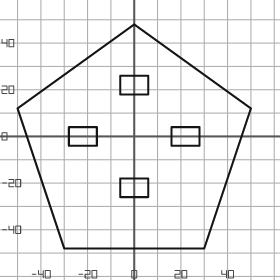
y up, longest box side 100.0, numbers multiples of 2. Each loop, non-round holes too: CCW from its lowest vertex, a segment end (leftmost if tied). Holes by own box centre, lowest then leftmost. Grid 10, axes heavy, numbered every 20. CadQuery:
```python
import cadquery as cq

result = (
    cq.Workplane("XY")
    .moveTo(-30.0, -48.0)
    .lineTo(30.0, -48.0)
    .lineTo(50.0, 12.0)
    .lineTo(0.0, 48.0)
    .lineTo(-50.0, 12.0)
    .close()
    .moveTo(-6.0, -26.0)
    .lineTo(6.0, -26.0)
    .lineTo(6.0, -18.0)
    .lineTo(-6.0, -18.0)
    .close()
    .moveTo(-28.0, -4.0)
    .lineTo(-16.0, -4.0)
    .lineTo(-16.0, 4.0)
    .lineTo(-28.0, 4.0)
    .close()
    .moveTo(16.0, -4.0)
    .lineTo(28.0, -4.0)
    .lineTo(28.0, 4.0)
    .lineTo(16.0, 4.0)
    .close()
    .moveTo(-6.0, 18.0)
    .lineTo(6.0, 18.0)
    .lineTo(6.0, 26.0)
    .lineTo(-6.0, 26.0)
    .close()
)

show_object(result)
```